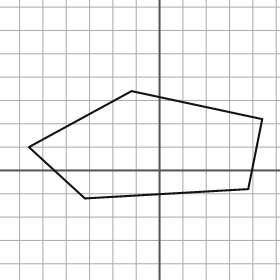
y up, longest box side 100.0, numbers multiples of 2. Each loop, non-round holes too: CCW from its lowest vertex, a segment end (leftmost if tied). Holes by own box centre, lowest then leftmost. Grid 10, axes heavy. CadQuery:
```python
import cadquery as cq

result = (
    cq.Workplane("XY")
    .moveTo(-32.0, -12.0)
    .lineTo(38.0, -8.0)
    .lineTo(44.0, 22.0)
    .lineTo(-12.0, 34.0)
    .lineTo(-56.0, 10.0)
    .close()
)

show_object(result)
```